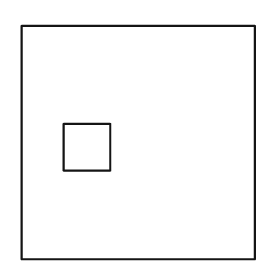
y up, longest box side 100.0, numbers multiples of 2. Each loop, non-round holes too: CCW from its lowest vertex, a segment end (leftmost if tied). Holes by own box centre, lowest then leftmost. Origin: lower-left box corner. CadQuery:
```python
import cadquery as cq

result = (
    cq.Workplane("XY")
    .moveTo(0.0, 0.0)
    .lineTo(100.0, 0.0)
    .lineTo(100.0, 100.0)
    .lineTo(0.0, 100.0)
    .close()
    .moveTo(18.0, 38.0)
    .lineTo(38.0, 38.0)
    .lineTo(38.0, 58.0)
    .lineTo(18.0, 58.0)
    .close()
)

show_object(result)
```